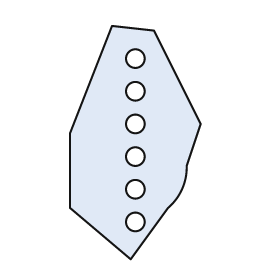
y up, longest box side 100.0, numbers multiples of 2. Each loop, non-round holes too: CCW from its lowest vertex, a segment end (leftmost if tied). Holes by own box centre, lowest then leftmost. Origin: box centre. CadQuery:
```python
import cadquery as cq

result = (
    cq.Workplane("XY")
    .moveTo(-2.0, -50.0)
    .lineTo(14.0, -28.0)
    .threePointArc((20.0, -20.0), (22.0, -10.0))
    .lineTo(28.0, 8.0)
    .lineTo(8.0, 48.0)
    .lineTo(-10.0, 50.0)
    .lineTo(-28.0, 4.0)
    .lineTo(-28.0, -28.0)
    .close()
    .moveTo(0.0, -34.0)
    .circle(4.0)
    .moveTo(0.0, -20.0)
    .circle(4.0)
    .moveTo(0.0, -6.0)
    .circle(4.0)
    .moveTo(0.0, 8.0)
    .circle(4.0)
    .moveTo(0.0, 22.0)
    .circle(4.0)
    .moveTo(0.0, 36.0)
    .circle(4.0)
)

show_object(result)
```